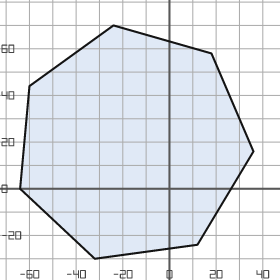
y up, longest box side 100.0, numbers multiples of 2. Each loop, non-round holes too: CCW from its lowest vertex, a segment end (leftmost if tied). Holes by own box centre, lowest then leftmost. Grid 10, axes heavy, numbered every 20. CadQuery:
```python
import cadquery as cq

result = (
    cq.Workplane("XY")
    .moveTo(-32.0, -30.0)
    .lineTo(12.0, -24.0)
    .lineTo(36.0, 16.0)
    .lineTo(18.0, 58.0)
    .lineTo(-24.0, 70.0)
    .lineTo(-60.0, 44.0)
    .lineTo(-64.0, 0.0)
    .close()
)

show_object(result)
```